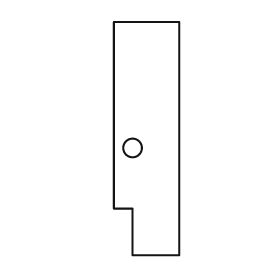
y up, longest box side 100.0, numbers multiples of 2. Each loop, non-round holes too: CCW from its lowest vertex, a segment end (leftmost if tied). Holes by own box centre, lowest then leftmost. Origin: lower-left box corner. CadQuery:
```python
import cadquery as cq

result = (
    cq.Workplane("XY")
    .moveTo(8.0, 0.0)
    .lineTo(28.0, 0.0)
    .lineTo(28.0, 100.0)
    .lineTo(0.0, 100.0)
    .lineTo(0.0, 20.0)
    .lineTo(8.0, 20.0)
    .close()
    .moveTo(8.0, 46.0)
    .circle(4.0)
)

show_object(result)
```